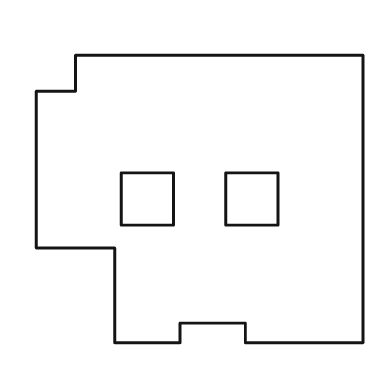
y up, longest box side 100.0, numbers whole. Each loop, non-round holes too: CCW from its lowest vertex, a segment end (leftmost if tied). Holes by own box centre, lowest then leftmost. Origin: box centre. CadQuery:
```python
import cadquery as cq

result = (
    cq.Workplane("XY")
    .moveTo(-26.0, -44.0)
    .lineTo(-6.0, -44.0)
    .lineTo(-6.0, -38.0)
    .lineTo(14.0, -38.0)
    .lineTo(14.0, -44.0)
    .lineTo(50.0, -44.0)
    .lineTo(50.0, 44.0)
    .lineTo(-38.0, 44.0)
    .lineTo(-38.0, 33.0)
    .lineTo(-50.0, 33.0)
    .lineTo(-50.0, -15.0)
    .lineTo(-26.0, -15.0)
    .close()
    .moveTo(-24.0, -8.0)
    .lineTo(-8.0, -8.0)
    .lineTo(-8.0, 8.0)
    .lineTo(-24.0, 8.0)
    .close()
    .moveTo(8.0, -8.0)
    .lineTo(24.0, -8.0)
    .lineTo(24.0, 8.0)
    .lineTo(8.0, 8.0)
    .close()
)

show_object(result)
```